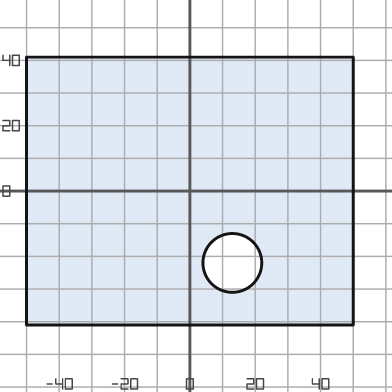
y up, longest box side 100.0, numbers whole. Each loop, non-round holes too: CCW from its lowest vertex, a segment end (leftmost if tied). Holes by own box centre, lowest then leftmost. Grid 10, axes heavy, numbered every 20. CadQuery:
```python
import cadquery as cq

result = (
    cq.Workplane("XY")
    .moveTo(-50.0, -41.0)
    .lineTo(50.0, -41.0)
    .lineTo(50.0, 41.0)
    .lineTo(-50.0, 41.0)
    .close()
    .moveTo(13.0, -22.0)
    .circle(9.0)
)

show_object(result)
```